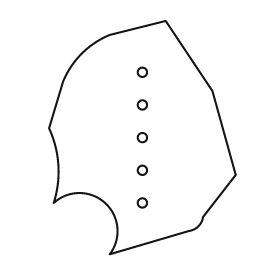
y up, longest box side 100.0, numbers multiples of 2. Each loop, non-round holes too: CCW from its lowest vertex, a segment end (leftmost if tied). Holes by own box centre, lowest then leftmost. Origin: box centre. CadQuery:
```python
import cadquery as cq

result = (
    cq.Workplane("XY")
    .moveTo(-14.0, -50.0)
    .lineTo(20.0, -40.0)
    .threePointArc((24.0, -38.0), (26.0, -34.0))
    .lineTo(40.0, -16.0)
    .lineTo(30.0, 20.0)
    .lineTo(10.0, 50.0)
    .lineTo(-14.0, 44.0)
    .threePointArc((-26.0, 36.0), (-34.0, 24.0))
    .lineTo(-40.0, 4.0)
    .threePointArc((-36.0, -12.0), (-38.0, -28.0))
    .threePointArc((-16.0, -28.0), (-14.0, -50.0))
    .close()
    .moveTo(0.0, -28.0)
    .circle(2.0)
    .moveTo(0.0, -14.0)
    .circle(2.0)
    .moveTo(0.0, 0.0)
    .circle(2.0)
    .moveTo(0.0, 14.0)
    .circle(2.0)
    .moveTo(0.0, 28.0)
    .circle(2.0)
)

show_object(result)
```